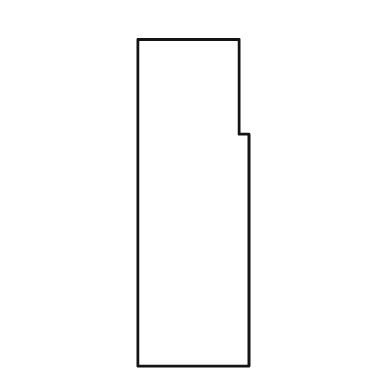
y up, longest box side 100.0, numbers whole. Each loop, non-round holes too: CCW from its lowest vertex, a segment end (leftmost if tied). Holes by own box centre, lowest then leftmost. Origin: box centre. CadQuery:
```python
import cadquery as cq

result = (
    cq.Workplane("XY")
    .moveTo(-17.0, -50.0)
    .lineTo(17.0, -50.0)
    .lineTo(17.0, 21.0)
    .lineTo(14.0, 21.0)
    .lineTo(14.0, 50.0)
    .lineTo(-17.0, 50.0)
    .close()
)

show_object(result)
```